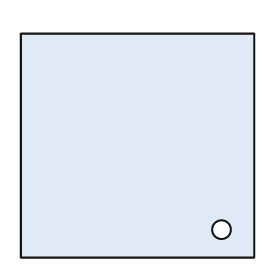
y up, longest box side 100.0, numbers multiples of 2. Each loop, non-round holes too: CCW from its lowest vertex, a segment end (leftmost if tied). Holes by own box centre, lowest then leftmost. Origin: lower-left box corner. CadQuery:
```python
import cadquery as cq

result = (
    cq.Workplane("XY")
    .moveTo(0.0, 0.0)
    .lineTo(100.0, 0.0)
    .lineTo(100.0, 96.0)
    .lineTo(0.0, 96.0)
    .close()
    .moveTo(86.0, 12.0)
    .circle(4.0)
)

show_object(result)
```